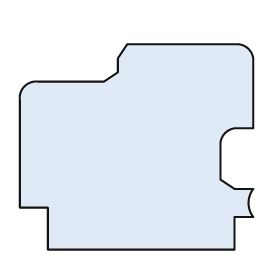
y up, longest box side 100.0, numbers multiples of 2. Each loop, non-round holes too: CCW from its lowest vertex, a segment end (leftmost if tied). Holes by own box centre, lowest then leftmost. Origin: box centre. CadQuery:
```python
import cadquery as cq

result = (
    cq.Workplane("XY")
    .moveTo(-38.0, -44.0)
    .lineTo(42.0, -44.0)
    .lineTo(42.0, -30.0)
    .lineTo(50.0, -30.0)
    .threePointArc((48.0, -24.0), (50.0, -18.0))
    .lineTo(42.0, -18.0)
    .lineTo(36.0, -14.0)
    .lineTo(36.0, 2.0)
    .threePointArc((38.0, 6.0), (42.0, 8.0))
    .lineTo(50.0, 8.0)
    .lineTo(50.0, 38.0)
    .threePointArc((48.0, 42.0), (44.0, 44.0))
    .lineTo(-4.0, 44.0)
    .lineTo(-8.0, 38.0)
    .lineTo(-8.0, 32.0)
    .lineTo(-14.0, 28.0)
    .lineTo(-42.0, 28.0)
    .threePointArc((-48.0, 26.0), (-50.0, 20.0))
    .lineTo(-50.0, -26.0)
    .lineTo(-38.0, -26.0)
    .close()
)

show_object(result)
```